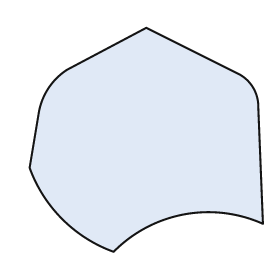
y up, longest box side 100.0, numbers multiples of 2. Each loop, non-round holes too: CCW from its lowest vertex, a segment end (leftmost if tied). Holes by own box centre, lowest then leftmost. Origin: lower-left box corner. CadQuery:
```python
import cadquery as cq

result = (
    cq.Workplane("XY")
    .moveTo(36.0, 0.0)
    .threePointArc((66.0, 16.0), (100.0, 12.0))
    .lineTo(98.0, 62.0)
    .threePointArc((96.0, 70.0), (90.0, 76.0))
    .lineTo(50.0, 96.0)
    .lineTo(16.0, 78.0)
    .threePointArc((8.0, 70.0), (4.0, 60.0))
    .lineTo(0.0, 36.0)
    .threePointArc((14.0, 14.0), (36.0, 0.0))
    .close()
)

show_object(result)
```